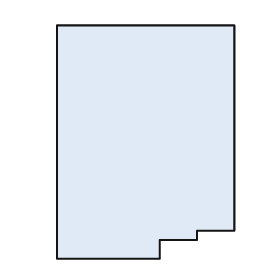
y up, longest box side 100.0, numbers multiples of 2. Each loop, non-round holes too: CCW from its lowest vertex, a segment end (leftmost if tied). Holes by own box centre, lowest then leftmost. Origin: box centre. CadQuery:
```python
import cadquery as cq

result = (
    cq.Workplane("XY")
    .moveTo(-38.0, -50.0)
    .lineTo(6.0, -50.0)
    .lineTo(6.0, -42.0)
    .lineTo(22.0, -42.0)
    .lineTo(22.0, -38.0)
    .lineTo(38.0, -38.0)
    .lineTo(38.0, 50.0)
    .lineTo(-38.0, 50.0)
    .close()
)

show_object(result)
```